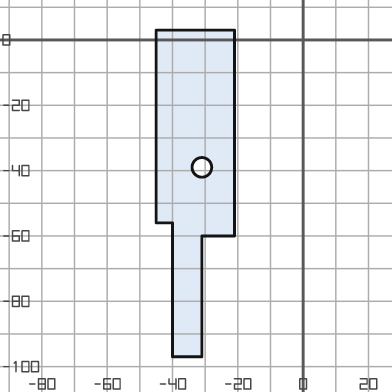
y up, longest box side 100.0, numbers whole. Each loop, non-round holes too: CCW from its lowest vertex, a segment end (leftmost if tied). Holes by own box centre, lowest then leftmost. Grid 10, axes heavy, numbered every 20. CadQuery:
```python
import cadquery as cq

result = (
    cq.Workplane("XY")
    .moveTo(-40.0, -97.0)
    .lineTo(-31.0, -97.0)
    .lineTo(-31.0, -60.0)
    .lineTo(-21.0, -60.0)
    .lineTo(-21.0, 3.0)
    .lineTo(-45.0, 3.0)
    .lineTo(-45.0, -56.0)
    .lineTo(-40.0, -56.0)
    .close()
    .moveTo(-31.0, -39.0)
    .circle(3.0)
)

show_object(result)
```